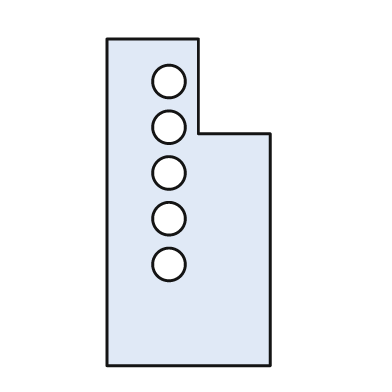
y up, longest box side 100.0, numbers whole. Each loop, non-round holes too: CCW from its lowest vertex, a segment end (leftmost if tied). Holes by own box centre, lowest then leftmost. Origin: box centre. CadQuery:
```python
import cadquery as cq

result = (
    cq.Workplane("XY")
    .moveTo(-25.0, -50.0)
    .lineTo(25.0, -50.0)
    .lineTo(25.0, 21.0)
    .lineTo(3.0, 21.0)
    .lineTo(3.0, 50.0)
    .lineTo(-25.0, 50.0)
    .close()
    .moveTo(-6.0, -19.0)
    .circle(5.0)
    .moveTo(-6.0, -5.0)
    .circle(5.0)
    .moveTo(-6.0, 9.0)
    .circle(5.0)
    .moveTo(-6.0, 23.0)
    .circle(5.0)
    .moveTo(-6.0, 37.0)
    .circle(5.0)
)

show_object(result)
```